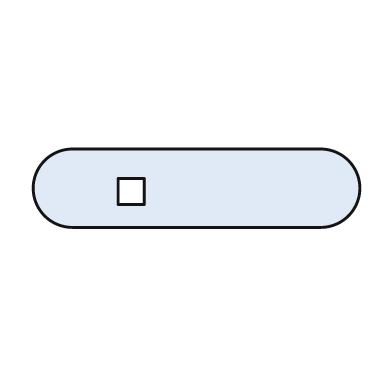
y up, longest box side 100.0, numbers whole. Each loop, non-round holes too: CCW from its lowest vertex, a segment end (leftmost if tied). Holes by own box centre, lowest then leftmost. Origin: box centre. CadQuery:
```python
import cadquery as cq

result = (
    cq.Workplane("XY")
    .moveTo(-38.0, -12.0)
    .lineTo(38.0, -12.0)
    .threePointArc((50.0, 0.0), (38.0, 12.0))
    .lineTo(-38.0, 12.0)
    .threePointArc((-50.0, 0.0), (-38.0, -12.0))
    .close()
    .moveTo(-24.0, -5.0)
    .lineTo(-16.0, -5.0)
    .lineTo(-16.0, 3.0)
    .lineTo(-24.0, 3.0)
    .close()
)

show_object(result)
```